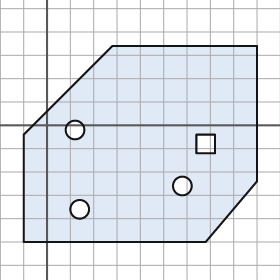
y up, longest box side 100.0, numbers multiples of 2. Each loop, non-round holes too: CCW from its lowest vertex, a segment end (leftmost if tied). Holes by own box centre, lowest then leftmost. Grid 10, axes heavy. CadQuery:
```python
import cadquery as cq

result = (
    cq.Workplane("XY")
    .moveTo(-10.0, -50.0)
    .lineTo(68.0, -50.0)
    .lineTo(90.0, -24.0)
    .lineTo(90.0, 34.0)
    .lineTo(28.0, 34.0)
    .lineTo(-10.0, -4.0)
    .close()
    .moveTo(14.0, -36.0)
    .circle(4.0)
    .moveTo(58.0, -26.0)
    .circle(4.0)
    .moveTo(64.0, -12.0)
    .lineTo(72.0, -12.0)
    .lineTo(72.0, -4.0)
    .lineTo(64.0, -4.0)
    .close()
    .moveTo(12.0, -2.0)
    .circle(4.0)
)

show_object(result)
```